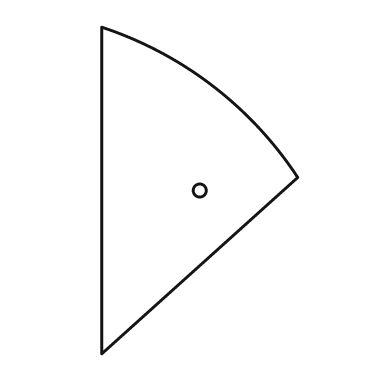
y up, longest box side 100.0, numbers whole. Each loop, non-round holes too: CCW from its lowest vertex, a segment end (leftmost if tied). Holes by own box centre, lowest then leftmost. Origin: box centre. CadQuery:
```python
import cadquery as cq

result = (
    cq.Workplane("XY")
    .moveTo(-30.0, -50.0)
    .lineTo(30.0, 4.0)
    .threePointArc((4.0, 32.0), (-30.0, 50.0))
    .close()
    .moveTo(0.0, 0.0)
    .circle(2.0)
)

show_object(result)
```